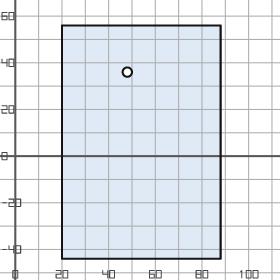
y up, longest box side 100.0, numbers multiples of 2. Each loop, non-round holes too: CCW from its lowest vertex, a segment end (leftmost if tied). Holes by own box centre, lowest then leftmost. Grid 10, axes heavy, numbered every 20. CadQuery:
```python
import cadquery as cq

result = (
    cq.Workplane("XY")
    .moveTo(20.0, -44.0)
    .lineTo(88.0, -44.0)
    .lineTo(88.0, 56.0)
    .lineTo(20.0, 56.0)
    .close()
    .moveTo(48.0, 36.0)
    .circle(2.0)
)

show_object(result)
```